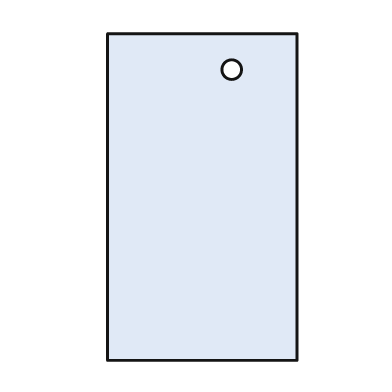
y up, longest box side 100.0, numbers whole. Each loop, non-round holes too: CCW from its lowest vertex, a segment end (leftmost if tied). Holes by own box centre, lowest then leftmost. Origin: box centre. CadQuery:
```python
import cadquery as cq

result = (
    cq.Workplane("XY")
    .moveTo(-29.0, -50.0)
    .lineTo(29.0, -50.0)
    .lineTo(29.0, 50.0)
    .lineTo(-29.0, 50.0)
    .close()
    .moveTo(9.0, 39.0)
    .circle(3.0)
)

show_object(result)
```